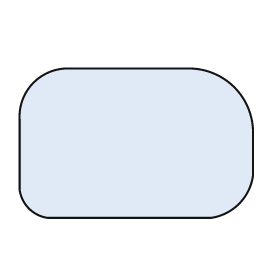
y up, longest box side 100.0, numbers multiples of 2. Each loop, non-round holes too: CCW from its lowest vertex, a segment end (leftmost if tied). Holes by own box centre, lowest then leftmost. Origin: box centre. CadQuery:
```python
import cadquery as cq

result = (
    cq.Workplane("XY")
    .moveTo(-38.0, -32.0)
    .lineTo(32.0, -32.0)
    .threePointArc((44.0, -26.0), (50.0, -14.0))
    .lineTo(50.0, 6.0)
    .threePointArc((42.0, 24.0), (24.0, 32.0))
    .lineTo(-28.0, 32.0)
    .threePointArc((-44.0, 26.0), (-50.0, 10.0))
    .lineTo(-50.0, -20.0)
    .threePointArc((-46.0, -28.0), (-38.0, -32.0))
    .close()
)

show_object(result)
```